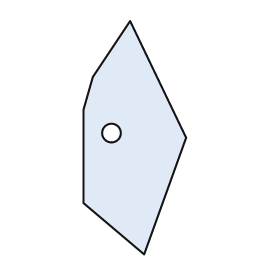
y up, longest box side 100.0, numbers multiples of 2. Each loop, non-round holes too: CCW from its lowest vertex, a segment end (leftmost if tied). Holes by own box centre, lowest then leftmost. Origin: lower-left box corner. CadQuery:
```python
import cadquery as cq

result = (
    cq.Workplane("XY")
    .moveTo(26.0, 0.0)
    .lineTo(44.0, 50.0)
    .lineTo(20.0, 100.0)
    .lineTo(4.0, 76.0)
    .lineTo(0.0, 62.0)
    .lineTo(0.0, 22.0)
    .close()
    .moveTo(12.0, 52.0)
    .circle(4.0)
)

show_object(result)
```